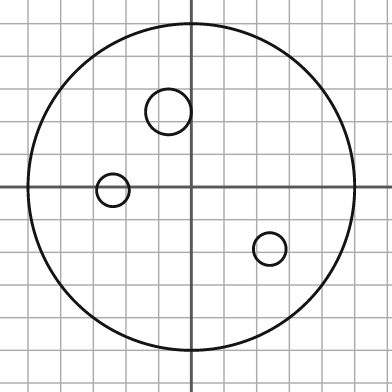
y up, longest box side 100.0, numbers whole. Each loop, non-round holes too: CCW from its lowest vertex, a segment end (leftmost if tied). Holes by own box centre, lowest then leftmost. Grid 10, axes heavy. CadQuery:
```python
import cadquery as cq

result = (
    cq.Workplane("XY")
    .moveTo(0.0, 0.0)
    .circle(50.0)
    .moveTo(24.0, -19.0)
    .circle(5.0)
    .moveTo(-24.0, -1.0)
    .circle(5.0)
    .moveTo(-7.0, 23.0)
    .circle(7.0)
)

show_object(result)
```